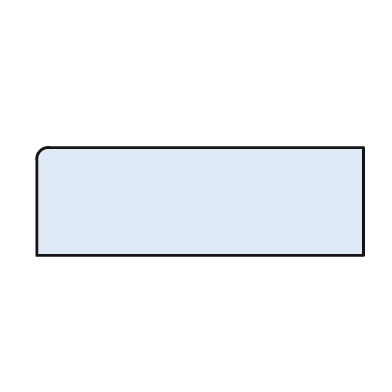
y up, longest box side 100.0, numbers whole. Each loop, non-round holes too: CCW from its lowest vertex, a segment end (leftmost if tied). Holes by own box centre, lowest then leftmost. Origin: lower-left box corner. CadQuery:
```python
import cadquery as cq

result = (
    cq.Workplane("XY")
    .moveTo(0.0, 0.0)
    .lineTo(100.0, 0.0)
    .lineTo(100.0, 33.0)
    .lineTo(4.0, 33.0)
    .threePointArc((1.0, 32.0), (0.0, 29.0))
    .close()
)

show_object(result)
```